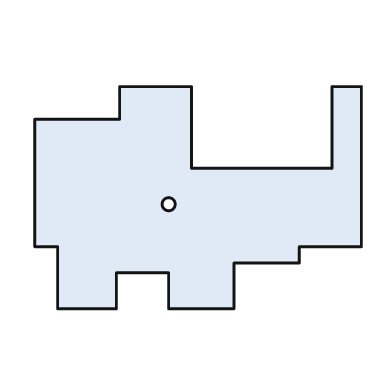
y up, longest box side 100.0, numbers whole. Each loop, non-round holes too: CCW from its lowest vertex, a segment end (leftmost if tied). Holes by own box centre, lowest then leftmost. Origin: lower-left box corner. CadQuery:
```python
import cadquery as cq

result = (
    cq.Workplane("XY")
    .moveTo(7.0, 0.0)
    .lineTo(25.0, 0.0)
    .lineTo(25.0, 11.0)
    .lineTo(41.0, 11.0)
    .lineTo(41.0, 0.0)
    .lineTo(61.0, 0.0)
    .lineTo(61.0, 14.0)
    .lineTo(81.0, 14.0)
    .lineTo(81.0, 19.0)
    .lineTo(100.0, 19.0)
    .lineTo(100.0, 68.0)
    .lineTo(91.0, 68.0)
    .lineTo(91.0, 43.0)
    .lineTo(48.0, 43.0)
    .lineTo(48.0, 68.0)
    .lineTo(26.0, 68.0)
    .lineTo(26.0, 58.0)
    .lineTo(0.0, 58.0)
    .lineTo(0.0, 19.0)
    .lineTo(7.0, 19.0)
    .close()
    .moveTo(41.0, 32.0)
    .circle(2.0)
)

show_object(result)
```